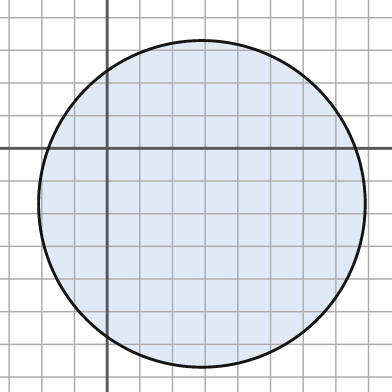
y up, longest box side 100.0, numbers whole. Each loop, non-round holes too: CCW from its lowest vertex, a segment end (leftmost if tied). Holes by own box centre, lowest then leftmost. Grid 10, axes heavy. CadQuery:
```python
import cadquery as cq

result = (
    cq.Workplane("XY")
    .moveTo(29.0, -17.0)
    .circle(50.0)
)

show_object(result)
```